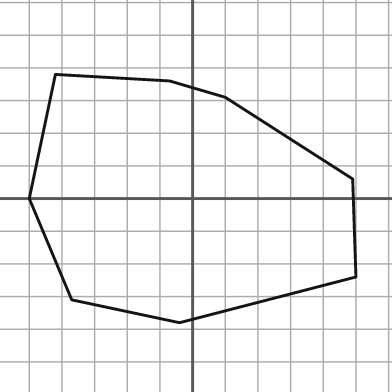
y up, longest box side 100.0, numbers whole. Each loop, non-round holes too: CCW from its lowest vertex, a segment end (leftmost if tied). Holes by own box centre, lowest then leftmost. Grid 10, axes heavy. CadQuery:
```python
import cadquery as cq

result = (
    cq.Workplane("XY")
    .moveTo(-4.0, -38.0)
    .lineTo(50.0, -24.0)
    .lineTo(49.0, 6.0)
    .lineTo(10.0, 31.0)
    .lineTo(-7.0, 36.0)
    .lineTo(-42.0, 38.0)
    .lineTo(-50.0, 0.0)
    .lineTo(-37.0, -31.0)
    .close()
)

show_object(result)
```